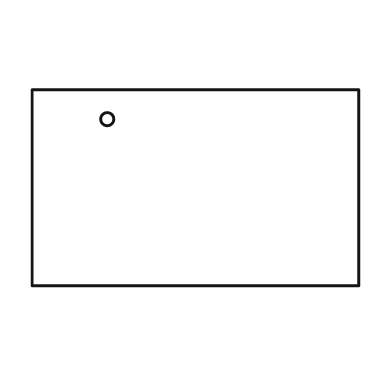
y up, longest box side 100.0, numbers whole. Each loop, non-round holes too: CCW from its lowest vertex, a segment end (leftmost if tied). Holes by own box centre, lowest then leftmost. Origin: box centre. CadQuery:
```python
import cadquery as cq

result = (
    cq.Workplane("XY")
    .moveTo(-50.0, -30.0)
    .lineTo(50.0, -30.0)
    .lineTo(50.0, 30.0)
    .lineTo(-50.0, 30.0)
    .close()
    .moveTo(-27.0, 21.0)
    .circle(2.0)
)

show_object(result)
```